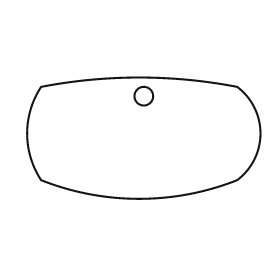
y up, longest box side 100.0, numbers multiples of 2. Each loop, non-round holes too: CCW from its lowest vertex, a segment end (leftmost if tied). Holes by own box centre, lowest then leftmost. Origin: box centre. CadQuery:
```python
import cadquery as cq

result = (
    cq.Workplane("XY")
    .moveTo(-44.0, -18.0)
    .threePointArc((-2.0, -26.0), (40.0, -18.0))
    .threePointArc((50.0, 2.0), (40.0, 22.0))
    .threePointArc((-2.0, 26.0), (-44.0, 22.0))
    .threePointArc((-50.0, 2.0), (-44.0, -18.0))
    .close()
    .moveTo(0.0, 18.0)
    .circle(4.0)
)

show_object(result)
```